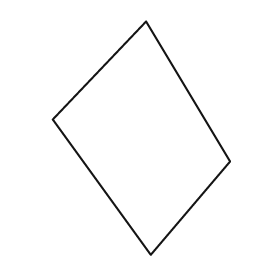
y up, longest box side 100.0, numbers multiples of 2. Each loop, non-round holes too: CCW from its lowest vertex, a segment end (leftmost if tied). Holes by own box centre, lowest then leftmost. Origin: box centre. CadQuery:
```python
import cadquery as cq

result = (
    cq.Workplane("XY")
    .moveTo(4.0, -50.0)
    .lineTo(38.0, -10.0)
    .lineTo(2.0, 50.0)
    .lineTo(-38.0, 8.0)
    .close()
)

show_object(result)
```